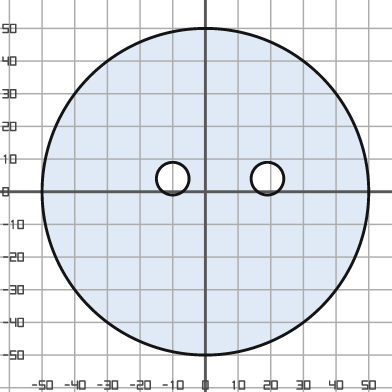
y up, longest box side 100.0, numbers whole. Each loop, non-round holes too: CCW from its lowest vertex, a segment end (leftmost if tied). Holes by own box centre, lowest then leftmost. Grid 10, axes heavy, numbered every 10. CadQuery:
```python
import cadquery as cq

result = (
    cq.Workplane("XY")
    .moveTo(0.0, 0.0)
    .circle(50.0)
    .moveTo(-10.0, 4.0)
    .circle(5.0)
    .moveTo(19.0, 4.0)
    .circle(5.0)
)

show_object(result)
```